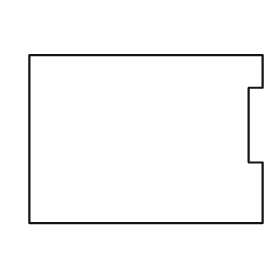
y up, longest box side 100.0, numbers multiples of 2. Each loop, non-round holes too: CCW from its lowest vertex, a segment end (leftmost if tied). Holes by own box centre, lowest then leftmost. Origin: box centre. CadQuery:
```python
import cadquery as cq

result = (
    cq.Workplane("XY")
    .moveTo(-50.0, -36.0)
    .lineTo(50.0, -36.0)
    .lineTo(50.0, -10.0)
    .lineTo(44.0, -10.0)
    .lineTo(44.0, 22.0)
    .lineTo(50.0, 22.0)
    .lineTo(50.0, 36.0)
    .lineTo(-50.0, 36.0)
    .close()
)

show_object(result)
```